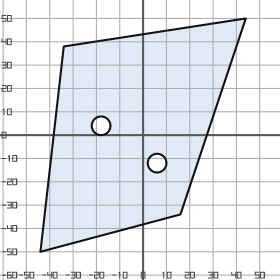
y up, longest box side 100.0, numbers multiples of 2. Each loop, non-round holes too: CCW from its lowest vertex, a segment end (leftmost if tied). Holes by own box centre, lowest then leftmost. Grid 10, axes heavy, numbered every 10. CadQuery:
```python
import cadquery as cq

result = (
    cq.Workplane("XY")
    .moveTo(-44.0, -50.0)
    .lineTo(16.0, -34.0)
    .lineTo(44.0, 50.0)
    .lineTo(-34.0, 38.0)
    .close()
    .moveTo(6.0, -12.0)
    .circle(4.0)
    .moveTo(-18.0, 4.0)
    .circle(4.0)
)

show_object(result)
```